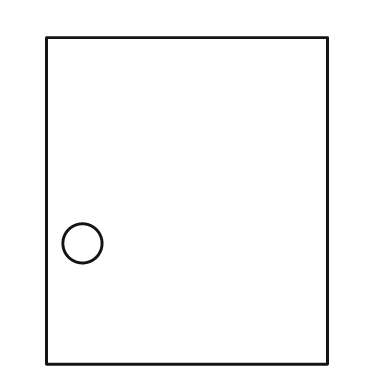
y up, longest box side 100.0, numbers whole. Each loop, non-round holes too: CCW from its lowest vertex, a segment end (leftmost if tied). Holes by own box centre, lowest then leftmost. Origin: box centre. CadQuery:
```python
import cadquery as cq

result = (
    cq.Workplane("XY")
    .moveTo(-43.0, -50.0)
    .lineTo(43.0, -50.0)
    .lineTo(43.0, 50.0)
    .lineTo(-43.0, 50.0)
    .close()
    .moveTo(-32.0, -13.0)
    .circle(6.0)
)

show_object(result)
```